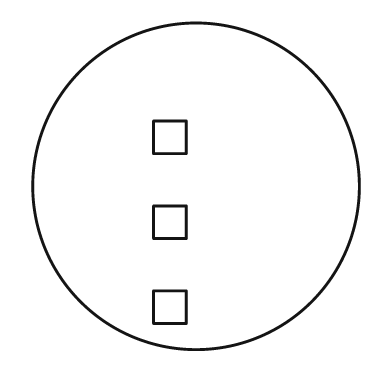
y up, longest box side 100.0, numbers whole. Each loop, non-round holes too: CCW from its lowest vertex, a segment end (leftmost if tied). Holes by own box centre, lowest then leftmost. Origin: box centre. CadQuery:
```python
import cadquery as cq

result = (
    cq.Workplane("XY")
    .moveTo(0.0, 0.0)
    .circle(50.0)
    .moveTo(-13.0, -42.0)
    .lineTo(-3.0, -42.0)
    .lineTo(-3.0, -32.0)
    .lineTo(-13.0, -32.0)
    .close()
    .moveTo(-13.0, -16.0)
    .lineTo(-3.0, -16.0)
    .lineTo(-3.0, -6.0)
    .lineTo(-13.0, -6.0)
    .close()
    .moveTo(-13.0, 10.0)
    .lineTo(-3.0, 10.0)
    .lineTo(-3.0, 20.0)
    .lineTo(-13.0, 20.0)
    .close()
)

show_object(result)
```